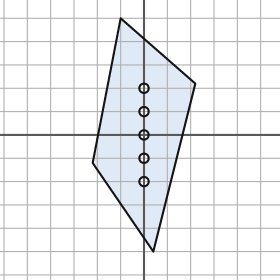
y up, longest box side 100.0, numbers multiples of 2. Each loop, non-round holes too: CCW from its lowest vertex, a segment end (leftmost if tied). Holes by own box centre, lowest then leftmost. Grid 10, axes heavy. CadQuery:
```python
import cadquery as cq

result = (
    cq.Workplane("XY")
    .moveTo(4.0, -50.0)
    .lineTo(22.0, 22.0)
    .lineTo(-10.0, 50.0)
    .lineTo(-22.0, -12.0)
    .close()
    .moveTo(0.0, -20.0)
    .circle(2.0)
    .moveTo(0.0, -10.0)
    .circle(2.0)
    .moveTo(0.0, 0.0)
    .circle(2.0)
    .moveTo(0.0, 10.0)
    .circle(2.0)
    .moveTo(0.0, 20.0)
    .circle(2.0)
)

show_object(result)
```